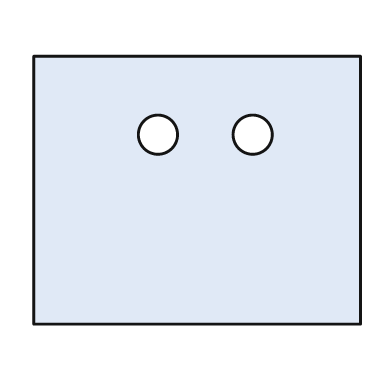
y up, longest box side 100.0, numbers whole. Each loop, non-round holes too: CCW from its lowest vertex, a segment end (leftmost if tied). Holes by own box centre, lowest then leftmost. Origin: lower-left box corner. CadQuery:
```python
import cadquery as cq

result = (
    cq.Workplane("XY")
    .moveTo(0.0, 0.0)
    .lineTo(100.0, 0.0)
    .lineTo(100.0, 82.0)
    .lineTo(0.0, 82.0)
    .close()
    .moveTo(38.0, 58.0)
    .circle(6.0)
    .moveTo(67.0, 58.0)
    .circle(6.0)
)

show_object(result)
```